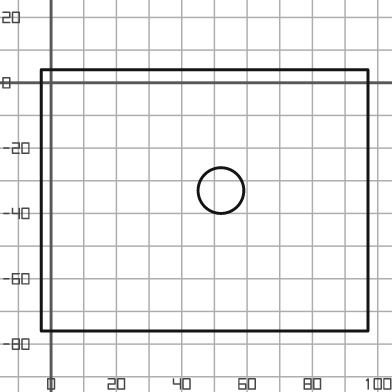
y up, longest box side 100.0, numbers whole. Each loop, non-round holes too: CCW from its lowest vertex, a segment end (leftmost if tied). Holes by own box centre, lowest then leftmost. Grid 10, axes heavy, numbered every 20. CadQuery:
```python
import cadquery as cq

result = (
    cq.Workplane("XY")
    .moveTo(-3.0, -76.0)
    .lineTo(97.0, -76.0)
    .lineTo(97.0, 4.0)
    .lineTo(-3.0, 4.0)
    .close()
    .moveTo(52.0, -33.0)
    .circle(7.0)
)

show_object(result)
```